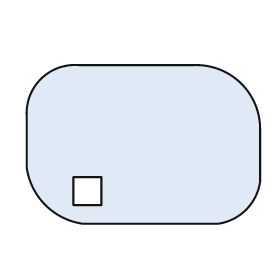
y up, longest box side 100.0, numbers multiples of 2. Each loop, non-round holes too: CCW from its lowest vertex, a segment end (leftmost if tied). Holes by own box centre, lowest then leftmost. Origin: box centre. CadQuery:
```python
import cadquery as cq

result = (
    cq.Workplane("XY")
    .moveTo(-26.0, -34.0)
    .lineTo(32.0, -34.0)
    .threePointArc((44.0, -28.0), (50.0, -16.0))
    .lineTo(50.0, 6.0)
    .threePointArc((42.0, 26.0), (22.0, 34.0))
    .lineTo(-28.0, 34.0)
    .threePointArc((-44.0, 28.0), (-50.0, 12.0))
    .lineTo(-50.0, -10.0)
    .threePointArc((-42.0, -26.0), (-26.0, -34.0))
    .close()
    .moveTo(-30.0, -26.0)
    .lineTo(-18.0, -26.0)
    .lineTo(-18.0, -14.0)
    .lineTo(-30.0, -14.0)
    .close()
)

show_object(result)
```